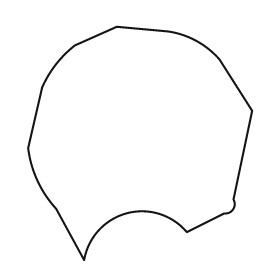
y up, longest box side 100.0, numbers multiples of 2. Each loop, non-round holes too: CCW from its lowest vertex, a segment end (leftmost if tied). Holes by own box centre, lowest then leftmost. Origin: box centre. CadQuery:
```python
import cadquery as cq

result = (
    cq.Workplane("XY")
    .moveTo(-24.0, -50.0)
    .threePointArc((-6.0, -30.0), (20.0, -38.0))
    .lineTo(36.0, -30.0)
    .threePointArc((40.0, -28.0), (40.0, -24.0))
    .lineTo(48.0, 14.0)
    .lineTo(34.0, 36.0)
    .threePointArc((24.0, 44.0), (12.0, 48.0))
    .lineTo(-10.0, 50.0)
    .lineTo(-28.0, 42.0)
    .threePointArc((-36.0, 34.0), (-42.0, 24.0))
    .lineTo(-48.0, -2.0)
    .threePointArc((-44.0, -16.0), (-36.0, -28.0))
    .close()
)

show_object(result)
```